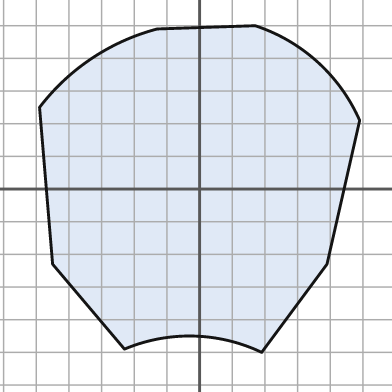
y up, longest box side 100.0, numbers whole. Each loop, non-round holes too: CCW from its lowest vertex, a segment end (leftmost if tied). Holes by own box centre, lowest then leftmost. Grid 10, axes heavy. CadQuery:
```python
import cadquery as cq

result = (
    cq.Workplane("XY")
    .moveTo(19.0, -50.0)
    .lineTo(39.0, -23.0)
    .lineTo(49.0, 21.0)
    .threePointArc((36.0, 39.0), (17.0, 50.0))
    .lineTo(-13.0, 49.0)
    .threePointArc((-33.0, 40.0), (-49.0, 25.0))
    .lineTo(-45.0, -23.0)
    .lineTo(-23.0, -49.0)
    .threePointArc((-2.0, -45.0), (19.0, -50.0))
    .close()
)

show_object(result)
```